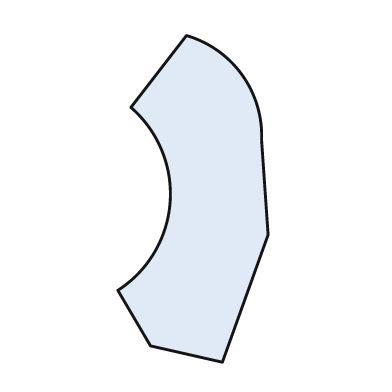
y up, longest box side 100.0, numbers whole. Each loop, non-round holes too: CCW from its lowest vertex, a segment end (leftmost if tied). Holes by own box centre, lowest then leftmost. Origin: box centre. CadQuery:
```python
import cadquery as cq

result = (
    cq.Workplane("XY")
    .moveTo(9.0, -50.0)
    .lineTo(23.0, -11.0)
    .lineTo(21.0, 18.0)
    .threePointArc((15.0, 38.0), (-2.0, 50.0))
    .lineTo(-19.0, 28.0)
    .threePointArc((-7.0, -1.0), (-23.0, -28.0))
    .lineTo(-13.0, -45.0)
    .close()
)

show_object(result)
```